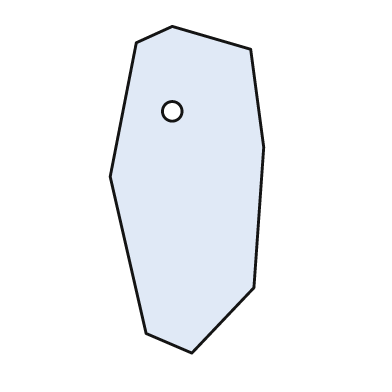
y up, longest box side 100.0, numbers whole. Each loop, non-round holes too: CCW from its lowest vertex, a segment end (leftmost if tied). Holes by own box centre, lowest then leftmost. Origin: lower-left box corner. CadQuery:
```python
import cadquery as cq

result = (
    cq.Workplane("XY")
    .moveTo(25.0, 0.0)
    .lineTo(44.0, 20.0)
    .lineTo(47.0, 63.0)
    .lineTo(43.0, 93.0)
    .lineTo(19.0, 100.0)
    .lineTo(8.0, 95.0)
    .lineTo(0.0, 54.0)
    .lineTo(11.0, 6.0)
    .close()
    .moveTo(19.0, 74.0)
    .circle(3.0)
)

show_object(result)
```